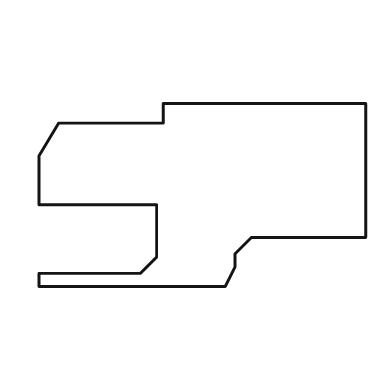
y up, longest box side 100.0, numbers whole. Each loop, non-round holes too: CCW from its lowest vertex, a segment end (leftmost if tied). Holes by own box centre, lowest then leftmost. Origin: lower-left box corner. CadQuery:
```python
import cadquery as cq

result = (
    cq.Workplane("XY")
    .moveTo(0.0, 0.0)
    .lineTo(57.0, 0.0)
    .lineTo(60.0, 6.0)
    .lineTo(60.0, 10.0)
    .lineTo(65.0, 15.0)
    .lineTo(100.0, 15.0)
    .lineTo(100.0, 56.0)
    .lineTo(38.0, 56.0)
    .lineTo(38.0, 50.0)
    .lineTo(6.0, 50.0)
    .lineTo(0.0, 40.0)
    .lineTo(0.0, 25.0)
    .lineTo(36.0, 25.0)
    .lineTo(36.0, 9.0)
    .lineTo(31.0, 4.0)
    .lineTo(0.0, 4.0)
    .close()
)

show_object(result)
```